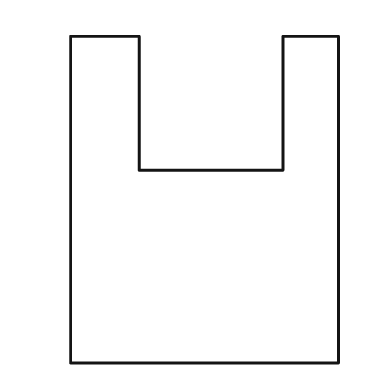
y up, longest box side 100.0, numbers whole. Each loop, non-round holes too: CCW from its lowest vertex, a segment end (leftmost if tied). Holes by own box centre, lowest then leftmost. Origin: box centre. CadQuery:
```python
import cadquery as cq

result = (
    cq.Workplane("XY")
    .moveTo(-41.0, -50.0)
    .lineTo(41.0, -50.0)
    .lineTo(41.0, 50.0)
    .lineTo(24.0, 50.0)
    .lineTo(24.0, 9.0)
    .lineTo(-20.0, 9.0)
    .lineTo(-20.0, 50.0)
    .lineTo(-41.0, 50.0)
    .close()
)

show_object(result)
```